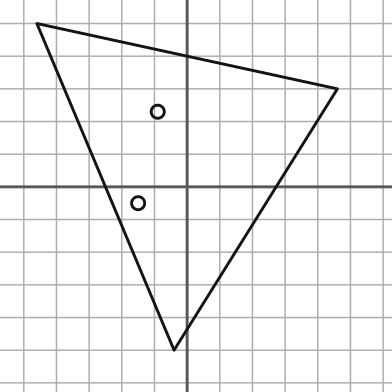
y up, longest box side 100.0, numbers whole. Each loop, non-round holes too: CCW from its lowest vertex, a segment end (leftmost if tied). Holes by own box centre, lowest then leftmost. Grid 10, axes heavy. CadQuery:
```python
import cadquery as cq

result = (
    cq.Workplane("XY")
    .moveTo(-4.0, -50.0)
    .lineTo(46.0, 30.0)
    .lineTo(-46.0, 50.0)
    .close()
    .moveTo(-15.0, -5.0)
    .circle(2.0)
    .moveTo(-9.0, 23.0)
    .circle(2.0)
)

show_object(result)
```